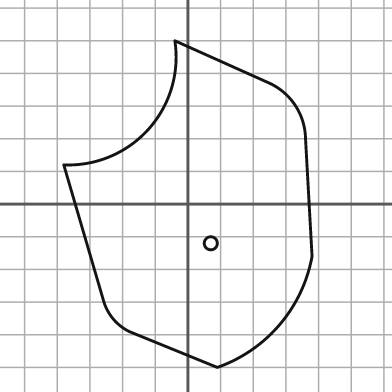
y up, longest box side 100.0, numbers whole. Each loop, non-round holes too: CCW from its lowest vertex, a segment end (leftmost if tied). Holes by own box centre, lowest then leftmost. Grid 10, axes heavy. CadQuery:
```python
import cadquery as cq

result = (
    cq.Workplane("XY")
    .moveTo(9.0, -50.0)
    .threePointArc((28.0, -37.0), (38.0, -16.0))
    .lineTo(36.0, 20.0)
    .threePointArc((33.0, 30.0), (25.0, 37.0))
    .lineTo(-4.0, 50.0)
    .threePointArc((-12.0, 23.0), (-38.0, 12.0))
    .lineTo(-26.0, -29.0)
    .threePointArc((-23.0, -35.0), (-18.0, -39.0))
    .close()
    .moveTo(7.0, -12.0)
    .circle(2.0)
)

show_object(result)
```